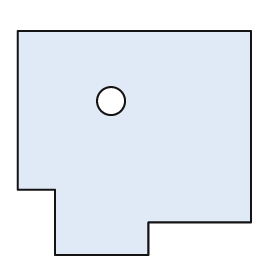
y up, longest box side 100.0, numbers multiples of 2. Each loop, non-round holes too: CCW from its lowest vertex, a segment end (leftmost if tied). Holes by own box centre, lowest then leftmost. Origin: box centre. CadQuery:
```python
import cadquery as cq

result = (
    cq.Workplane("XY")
    .moveTo(-34.0, -48.0)
    .lineTo(6.0, -48.0)
    .lineTo(6.0, -34.0)
    .lineTo(50.0, -34.0)
    .lineTo(50.0, 48.0)
    .lineTo(-50.0, 48.0)
    .lineTo(-50.0, -20.0)
    .lineTo(-34.0, -20.0)
    .close()
    .moveTo(-10.0, 18.0)
    .circle(6.0)
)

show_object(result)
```